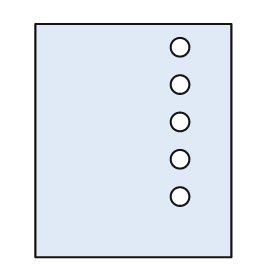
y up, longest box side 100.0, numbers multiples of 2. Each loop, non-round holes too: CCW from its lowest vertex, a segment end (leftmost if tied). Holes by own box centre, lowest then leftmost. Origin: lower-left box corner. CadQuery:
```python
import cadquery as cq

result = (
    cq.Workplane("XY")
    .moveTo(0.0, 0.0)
    .lineTo(84.0, 0.0)
    .lineTo(84.0, 100.0)
    .lineTo(0.0, 100.0)
    .close()
    .moveTo(62.0, 26.0)
    .circle(4.0)
    .moveTo(62.0, 42.0)
    .circle(4.0)
    .moveTo(62.0, 58.0)
    .circle(4.0)
    .moveTo(62.0, 74.0)
    .circle(4.0)
    .moveTo(62.0, 90.0)
    .circle(4.0)
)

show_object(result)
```